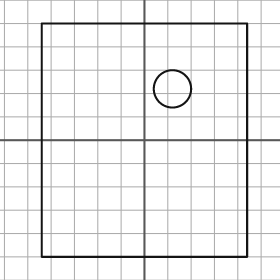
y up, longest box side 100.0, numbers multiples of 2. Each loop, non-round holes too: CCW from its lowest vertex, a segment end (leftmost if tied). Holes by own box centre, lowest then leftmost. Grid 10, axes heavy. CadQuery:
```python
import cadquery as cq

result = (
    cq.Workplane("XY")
    .moveTo(-44.0, -50.0)
    .lineTo(44.0, -50.0)
    .lineTo(44.0, 50.0)
    .lineTo(-44.0, 50.0)
    .close()
    .moveTo(12.0, 22.0)
    .circle(8.0)
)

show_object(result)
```